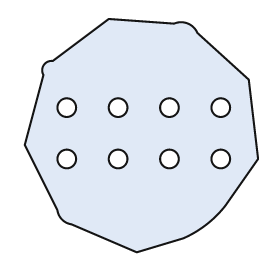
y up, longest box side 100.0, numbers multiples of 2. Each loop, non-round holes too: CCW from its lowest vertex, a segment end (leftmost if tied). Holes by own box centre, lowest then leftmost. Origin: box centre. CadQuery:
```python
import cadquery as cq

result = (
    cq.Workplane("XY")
    .moveTo(-2.0, -50.0)
    .lineTo(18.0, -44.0)
    .threePointArc((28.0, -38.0), (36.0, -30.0))
    .lineTo(50.0, -10.0)
    .lineTo(46.0, 24.0)
    .lineTo(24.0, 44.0)
    .threePointArc((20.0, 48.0), (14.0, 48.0))
    .lineTo(-14.0, 50.0)
    .lineTo(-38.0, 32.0)
    .threePointArc((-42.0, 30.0), (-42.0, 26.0))
    .lineTo(-50.0, -4.0)
    .lineTo(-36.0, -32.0)
    .threePointArc((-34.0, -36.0), (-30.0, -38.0))
    .close()
    .moveTo(-32.0, -10.0)
    .circle(4.0)
    .moveTo(-10.0, -10.0)
    .circle(4.0)
    .moveTo(12.0, -10.0)
    .circle(4.0)
    .moveTo(34.0, -10.0)
    .circle(4.0)
    .moveTo(-32.0, 12.0)
    .circle(4.0)
    .moveTo(-10.0, 12.0)
    .circle(4.0)
    .moveTo(12.0, 12.0)
    .circle(4.0)
    .moveTo(34.0, 12.0)
    .circle(4.0)
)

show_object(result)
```